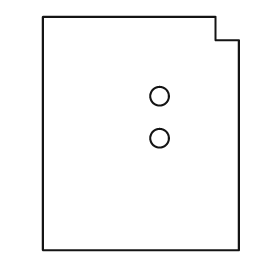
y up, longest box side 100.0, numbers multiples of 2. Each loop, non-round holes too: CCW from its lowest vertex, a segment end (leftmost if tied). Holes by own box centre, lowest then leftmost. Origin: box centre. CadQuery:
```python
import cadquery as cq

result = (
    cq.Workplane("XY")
    .moveTo(-42.0, -50.0)
    .lineTo(42.0, -50.0)
    .lineTo(42.0, 40.0)
    .lineTo(32.0, 40.0)
    .lineTo(32.0, 50.0)
    .lineTo(-42.0, 50.0)
    .close()
    .moveTo(8.0, -2.0)
    .circle(4.0)
    .moveTo(8.0, 16.0)
    .circle(4.0)
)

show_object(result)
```